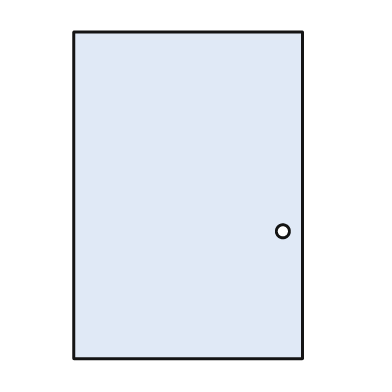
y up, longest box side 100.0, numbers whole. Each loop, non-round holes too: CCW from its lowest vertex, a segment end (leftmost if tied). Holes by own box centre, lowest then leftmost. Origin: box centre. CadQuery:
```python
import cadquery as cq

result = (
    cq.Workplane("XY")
    .moveTo(-35.0, -50.0)
    .lineTo(35.0, -50.0)
    .lineTo(35.0, 50.0)
    .lineTo(-35.0, 50.0)
    .close()
    .moveTo(29.0, -11.0)
    .circle(2.0)
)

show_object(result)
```